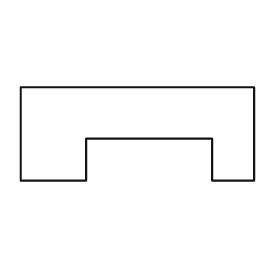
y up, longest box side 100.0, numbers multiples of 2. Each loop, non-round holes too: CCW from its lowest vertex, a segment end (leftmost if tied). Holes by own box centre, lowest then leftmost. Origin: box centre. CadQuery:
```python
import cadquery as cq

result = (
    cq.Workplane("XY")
    .moveTo(-50.0, -20.0)
    .lineTo(-22.0, -20.0)
    .lineTo(-22.0, -2.0)
    .lineTo(32.0, -2.0)
    .lineTo(32.0, -20.0)
    .lineTo(50.0, -20.0)
    .lineTo(50.0, 20.0)
    .lineTo(-50.0, 20.0)
    .close()
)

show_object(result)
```